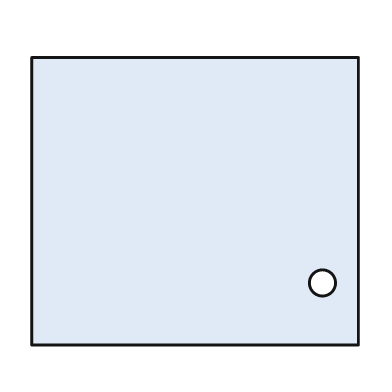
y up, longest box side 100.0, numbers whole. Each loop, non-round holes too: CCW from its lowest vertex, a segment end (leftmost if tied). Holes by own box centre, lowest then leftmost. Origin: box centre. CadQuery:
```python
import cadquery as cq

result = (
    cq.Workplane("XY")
    .moveTo(-50.0, -44.0)
    .lineTo(50.0, -44.0)
    .lineTo(50.0, 44.0)
    .lineTo(-50.0, 44.0)
    .close()
    .moveTo(39.0, -25.0)
    .circle(4.0)
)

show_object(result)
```